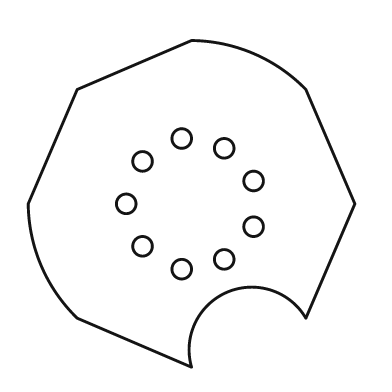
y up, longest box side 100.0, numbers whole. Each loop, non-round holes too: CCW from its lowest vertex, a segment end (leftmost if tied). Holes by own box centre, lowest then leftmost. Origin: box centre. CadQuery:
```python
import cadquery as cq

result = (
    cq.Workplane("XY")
    .moveTo(0.0, -50.0)
    .threePointArc((11.0, -27.0), (35.0, -35.0))
    .lineTo(50.0, 0.0)
    .lineTo(35.0, 35.0)
    .threePointArc((19.0, 46.0), (0.0, 50.0))
    .lineTo(-35.0, 35.0)
    .lineTo(-50.0, 0.0)
    .threePointArc((-46.0, -19.0), (-35.0, -35.0))
    .close()
    .moveTo(-3.0, -20.0)
    .circle(3.0)
    .moveTo(10.0, -17.0)
    .circle(3.0)
    .moveTo(-15.0, -13.0)
    .circle(3.0)
    .moveTo(19.0, -7.0)
    .circle(3.0)
    .moveTo(-20.0, 0.0)
    .circle(3.0)
    .moveTo(19.0, 7.0)
    .circle(3.0)
    .moveTo(-15.0, 13.0)
    .circle(3.0)
    .moveTo(10.0, 17.0)
    .circle(3.0)
    .moveTo(-3.0, 20.0)
    .circle(3.0)
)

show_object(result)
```